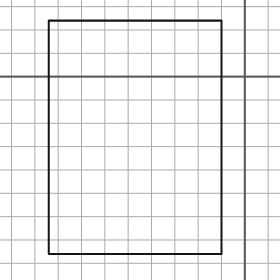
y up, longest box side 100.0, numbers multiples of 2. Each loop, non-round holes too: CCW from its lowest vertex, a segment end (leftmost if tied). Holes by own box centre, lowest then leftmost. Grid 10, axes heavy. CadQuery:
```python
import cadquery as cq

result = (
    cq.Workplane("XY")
    .moveTo(-84.0, -76.0)
    .lineTo(-10.0, -76.0)
    .lineTo(-10.0, 24.0)
    .lineTo(-84.0, 24.0)
    .close()
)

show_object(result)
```